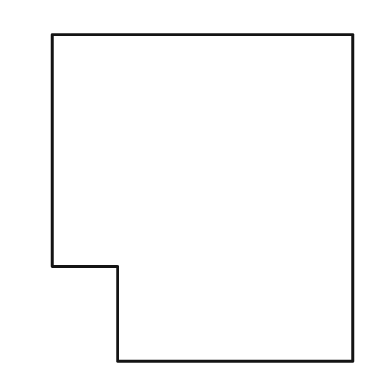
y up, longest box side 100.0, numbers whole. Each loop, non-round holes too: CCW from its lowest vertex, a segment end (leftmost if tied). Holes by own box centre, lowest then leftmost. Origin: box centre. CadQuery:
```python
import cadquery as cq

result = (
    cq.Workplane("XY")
    .moveTo(-26.0, -50.0)
    .lineTo(46.0, -50.0)
    .lineTo(46.0, 50.0)
    .lineTo(-46.0, 50.0)
    .lineTo(-46.0, -21.0)
    .lineTo(-26.0, -21.0)
    .close()
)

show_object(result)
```